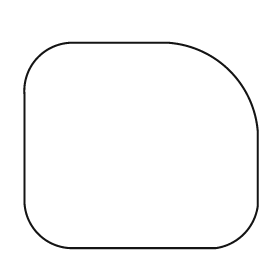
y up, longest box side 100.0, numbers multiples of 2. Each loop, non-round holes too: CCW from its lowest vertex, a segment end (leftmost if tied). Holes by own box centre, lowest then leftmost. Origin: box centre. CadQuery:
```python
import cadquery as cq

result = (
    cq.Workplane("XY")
    .moveTo(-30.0, -44.0)
    .lineTo(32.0, -44.0)
    .threePointArc((44.0, -38.0), (50.0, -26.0))
    .lineTo(50.0, 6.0)
    .threePointArc((38.0, 32.0), (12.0, 44.0))
    .lineTo(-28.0, 44.0)
    .threePointArc((-44.0, 38.0), (-50.0, 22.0))
    .lineTo(-50.0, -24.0)
    .threePointArc((-44.0, -38.0), (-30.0, -44.0))
    .close()
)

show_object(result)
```